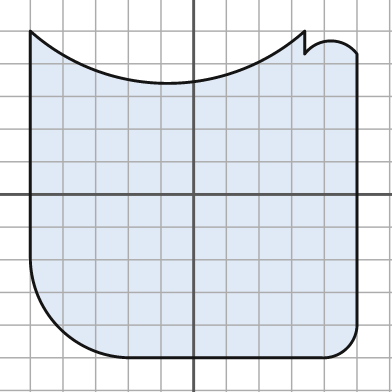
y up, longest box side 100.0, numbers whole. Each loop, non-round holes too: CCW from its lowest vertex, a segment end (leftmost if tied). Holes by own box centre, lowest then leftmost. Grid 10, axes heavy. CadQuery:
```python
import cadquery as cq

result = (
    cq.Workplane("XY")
    .moveTo(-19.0, -50.0)
    .lineTo(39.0, -50.0)
    .threePointArc((47.0, -47.0), (50.0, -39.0))
    .lineTo(50.0, 43.0)
    .threePointArc((42.0, 47.0), (34.0, 43.0))
    .lineTo(34.0, 50.0)
    .threePointArc((-8.0, 34.0), (-50.0, 50.0))
    .lineTo(-50.0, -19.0)
    .threePointArc((-41.0, -41.0), (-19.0, -50.0))
    .close()
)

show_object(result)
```